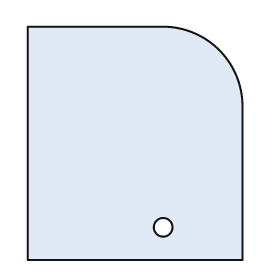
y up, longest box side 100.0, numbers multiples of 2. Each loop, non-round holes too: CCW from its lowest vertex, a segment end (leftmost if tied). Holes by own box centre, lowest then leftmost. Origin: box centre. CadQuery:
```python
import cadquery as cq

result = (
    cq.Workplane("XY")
    .moveTo(-46.0, -50.0)
    .lineTo(46.0, -50.0)
    .lineTo(46.0, 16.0)
    .threePointArc((36.0, 40.0), (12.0, 50.0))
    .lineTo(-46.0, 50.0)
    .close()
    .moveTo(12.0, -36.0)
    .circle(4.0)
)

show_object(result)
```